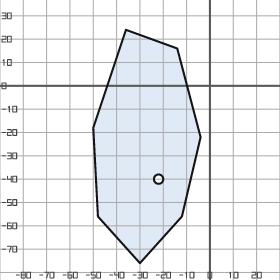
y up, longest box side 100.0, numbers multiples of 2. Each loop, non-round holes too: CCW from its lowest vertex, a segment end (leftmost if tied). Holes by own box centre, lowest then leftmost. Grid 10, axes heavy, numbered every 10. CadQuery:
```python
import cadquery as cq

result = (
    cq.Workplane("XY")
    .moveTo(-30.0, -76.0)
    .lineTo(-12.0, -56.0)
    .lineTo(-4.0, -22.0)
    .lineTo(-14.0, 16.0)
    .lineTo(-36.0, 24.0)
    .lineTo(-50.0, -18.0)
    .lineTo(-48.0, -56.0)
    .close()
    .moveTo(-22.0, -40.0)
    .circle(2.0)
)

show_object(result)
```